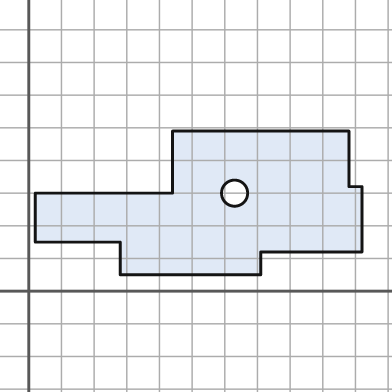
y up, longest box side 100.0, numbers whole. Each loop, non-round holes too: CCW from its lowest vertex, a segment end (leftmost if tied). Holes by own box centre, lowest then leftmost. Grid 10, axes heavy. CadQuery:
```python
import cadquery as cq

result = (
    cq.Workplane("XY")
    .moveTo(28.0, 5.0)
    .lineTo(71.0, 5.0)
    .lineTo(71.0, 12.0)
    .lineTo(102.0, 12.0)
    .lineTo(102.0, 32.0)
    .lineTo(98.0, 32.0)
    .lineTo(98.0, 49.0)
    .lineTo(44.0, 49.0)
    .lineTo(44.0, 30.0)
    .lineTo(2.0, 30.0)
    .lineTo(2.0, 15.0)
    .lineTo(28.0, 15.0)
    .close()
    .moveTo(63.0, 30.0)
    .circle(4.0)
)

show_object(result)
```